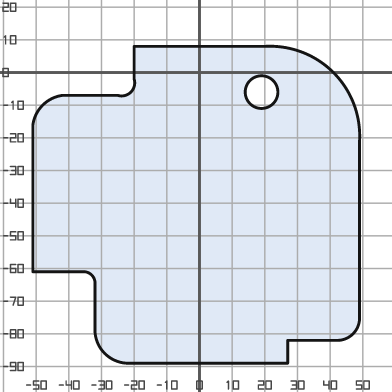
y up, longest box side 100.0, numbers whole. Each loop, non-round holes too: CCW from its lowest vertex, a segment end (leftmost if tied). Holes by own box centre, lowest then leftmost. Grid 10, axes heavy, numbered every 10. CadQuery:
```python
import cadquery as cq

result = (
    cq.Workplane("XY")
    .moveTo(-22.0, -89.0)
    .lineTo(27.0, -89.0)
    .lineTo(27.0, -82.0)
    .lineTo(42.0, -82.0)
    .threePointArc((47.0, -80.0), (49.0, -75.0))
    .lineTo(49.0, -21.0)
    .threePointArc((41.0, 0.0), (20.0, 8.0))
    .lineTo(-20.0, 8.0)
    .lineTo(-20.0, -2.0)
    .threePointArc((-21.0, -6.0), (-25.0, -7.0))
    .lineTo(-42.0, -7.0)
    .threePointArc((-48.0, -10.0), (-51.0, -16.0))
    .lineTo(-51.0, -61.0)
    .lineTo(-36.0, -61.0)
    .threePointArc((-33.0, -62.0), (-32.0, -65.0))
    .lineTo(-32.0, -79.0)
    .threePointArc((-29.0, -86.0), (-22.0, -89.0))
    .close()
    .moveTo(19.0, -6.0)
    .circle(5.0)
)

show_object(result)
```